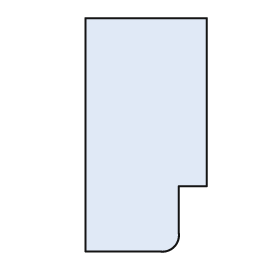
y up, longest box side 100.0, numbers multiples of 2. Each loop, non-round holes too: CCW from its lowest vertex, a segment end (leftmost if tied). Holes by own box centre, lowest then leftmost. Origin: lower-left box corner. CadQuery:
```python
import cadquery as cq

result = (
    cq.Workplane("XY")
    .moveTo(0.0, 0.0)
    .lineTo(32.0, 0.0)
    .threePointArc((38.0, 2.0), (40.0, 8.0))
    .lineTo(40.0, 28.0)
    .lineTo(52.0, 28.0)
    .lineTo(52.0, 100.0)
    .lineTo(0.0, 100.0)
    .close()
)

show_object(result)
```